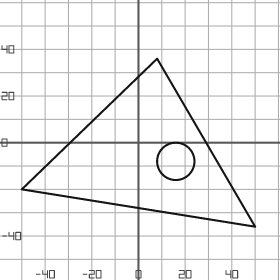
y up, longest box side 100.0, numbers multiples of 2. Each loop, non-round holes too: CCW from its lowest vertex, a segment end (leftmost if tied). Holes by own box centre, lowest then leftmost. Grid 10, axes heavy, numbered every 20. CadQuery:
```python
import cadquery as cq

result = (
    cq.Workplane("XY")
    .moveTo(50.0, -36.0)
    .lineTo(8.0, 36.0)
    .lineTo(-50.0, -20.0)
    .close()
    .moveTo(16.0, -8.0)
    .circle(8.0)
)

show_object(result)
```